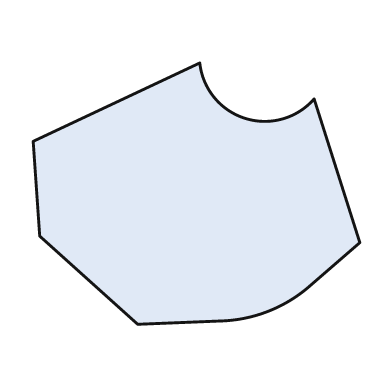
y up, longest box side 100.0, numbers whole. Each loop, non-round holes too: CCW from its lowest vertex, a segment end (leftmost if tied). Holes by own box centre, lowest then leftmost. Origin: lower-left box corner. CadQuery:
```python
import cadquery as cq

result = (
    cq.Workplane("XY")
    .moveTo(32.0, 0.0)
    .lineTo(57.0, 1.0)
    .threePointArc((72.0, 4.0), (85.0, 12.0))
    .lineTo(100.0, 25.0)
    .lineTo(86.0, 69.0)
    .threePointArc((65.0, 63.0), (51.0, 80.0))
    .lineTo(0.0, 56.0)
    .lineTo(2.0, 27.0)
    .close()
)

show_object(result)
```